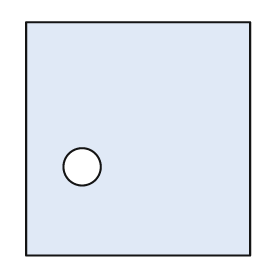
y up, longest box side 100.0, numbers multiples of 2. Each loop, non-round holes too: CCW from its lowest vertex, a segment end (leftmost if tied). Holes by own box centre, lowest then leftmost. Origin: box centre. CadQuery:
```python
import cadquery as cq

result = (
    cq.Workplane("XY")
    .moveTo(-48.0, -50.0)
    .lineTo(48.0, -50.0)
    .lineTo(48.0, 50.0)
    .lineTo(-48.0, 50.0)
    .close()
    .moveTo(-24.0, -12.0)
    .circle(8.0)
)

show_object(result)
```